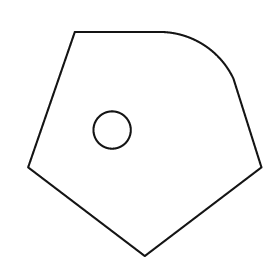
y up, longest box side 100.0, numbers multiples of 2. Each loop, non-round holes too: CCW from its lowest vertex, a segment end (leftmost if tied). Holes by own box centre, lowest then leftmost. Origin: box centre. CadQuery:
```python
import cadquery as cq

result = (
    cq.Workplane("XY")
    .moveTo(0.0, -48.0)
    .lineTo(50.0, -10.0)
    .lineTo(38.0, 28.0)
    .threePointArc((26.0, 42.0), (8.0, 48.0))
    .lineTo(-30.0, 48.0)
    .lineTo(-50.0, -10.0)
    .close()
    .moveTo(-14.0, 6.0)
    .circle(8.0)
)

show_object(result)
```